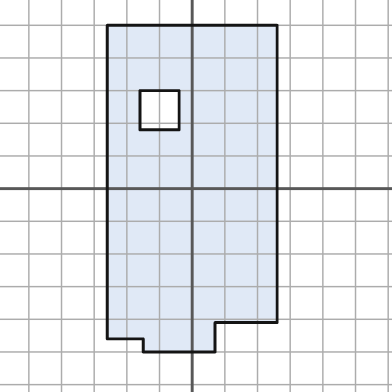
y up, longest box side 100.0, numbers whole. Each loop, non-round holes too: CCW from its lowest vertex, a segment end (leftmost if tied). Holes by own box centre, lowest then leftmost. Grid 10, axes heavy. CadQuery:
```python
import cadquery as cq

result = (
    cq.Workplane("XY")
    .moveTo(-15.0, -50.0)
    .lineTo(7.0, -50.0)
    .lineTo(7.0, -41.0)
    .lineTo(26.0, -41.0)
    .lineTo(26.0, 50.0)
    .lineTo(-26.0, 50.0)
    .lineTo(-26.0, -46.0)
    .lineTo(-15.0, -46.0)
    .close()
    .moveTo(-16.0, 18.0)
    .lineTo(-4.0, 18.0)
    .lineTo(-4.0, 30.0)
    .lineTo(-16.0, 30.0)
    .close()
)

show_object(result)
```